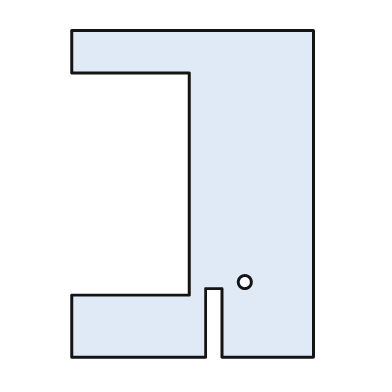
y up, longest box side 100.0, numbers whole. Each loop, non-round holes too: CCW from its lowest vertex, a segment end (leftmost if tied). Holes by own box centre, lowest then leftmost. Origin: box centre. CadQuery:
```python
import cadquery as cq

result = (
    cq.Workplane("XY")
    .moveTo(-37.0, -50.0)
    .lineTo(4.0, -50.0)
    .lineTo(4.0, -29.0)
    .lineTo(9.0, -29.0)
    .lineTo(9.0, -50.0)
    .lineTo(37.0, -50.0)
    .lineTo(37.0, 50.0)
    .lineTo(-37.0, 50.0)
    .lineTo(-37.0, 37.0)
    .lineTo(-1.0, 37.0)
    .lineTo(-1.0, -31.0)
    .lineTo(-37.0, -31.0)
    .close()
    .moveTo(16.0, -27.0)
    .circle(2.0)
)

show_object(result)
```